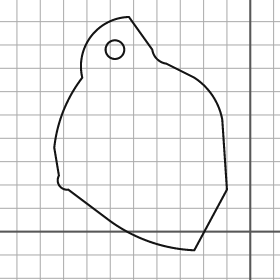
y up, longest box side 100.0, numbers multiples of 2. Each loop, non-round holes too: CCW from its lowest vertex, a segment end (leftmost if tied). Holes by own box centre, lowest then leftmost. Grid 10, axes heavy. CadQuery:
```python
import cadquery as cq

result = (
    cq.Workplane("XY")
    .moveTo(-24.0, -8.0)
    .lineTo(-10.0, 18.0)
    .lineTo(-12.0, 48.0)
    .threePointArc((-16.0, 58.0), (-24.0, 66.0))
    .lineTo(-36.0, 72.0)
    .threePointArc((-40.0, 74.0), (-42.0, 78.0))
    .lineTo(-52.0, 92.0)
    .threePointArc((-68.0, 84.0), (-72.0, 66.0))
    .threePointArc((-80.0, 52.0), (-84.0, 36.0))
    .lineTo(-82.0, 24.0)
    .threePointArc((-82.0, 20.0), (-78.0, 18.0))
    .lineTo(-62.0, 6.0)
    .threePointArc((-44.0, -4.0), (-24.0, -8.0))
    .close()
    .moveTo(-58.0, 78.0)
    .circle(4.0)
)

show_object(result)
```